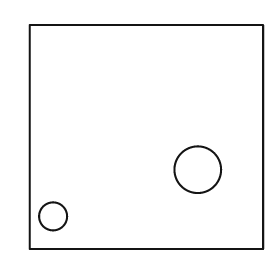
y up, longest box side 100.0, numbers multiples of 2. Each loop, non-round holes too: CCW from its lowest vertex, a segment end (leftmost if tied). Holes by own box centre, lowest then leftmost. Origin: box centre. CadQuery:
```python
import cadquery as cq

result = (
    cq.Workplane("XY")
    .moveTo(-50.0, -48.0)
    .lineTo(50.0, -48.0)
    .lineTo(50.0, 48.0)
    .lineTo(-50.0, 48.0)
    .close()
    .moveTo(-40.0, -34.0)
    .circle(6.0)
    .moveTo(22.0, -14.0)
    .circle(10.0)
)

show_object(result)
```